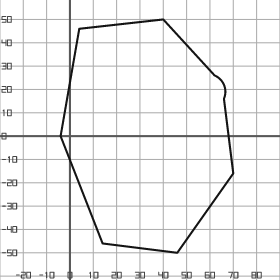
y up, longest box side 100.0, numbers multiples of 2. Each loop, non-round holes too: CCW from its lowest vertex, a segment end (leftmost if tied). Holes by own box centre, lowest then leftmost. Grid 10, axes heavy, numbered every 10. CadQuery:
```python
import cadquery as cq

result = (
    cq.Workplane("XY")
    .moveTo(46.0, -50.0)
    .lineTo(70.0, -16.0)
    .lineTo(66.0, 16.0)
    .threePointArc((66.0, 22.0), (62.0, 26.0))
    .lineTo(40.0, 50.0)
    .lineTo(4.0, 46.0)
    .lineTo(-4.0, 0.0)
    .lineTo(14.0, -46.0)
    .close()
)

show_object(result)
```